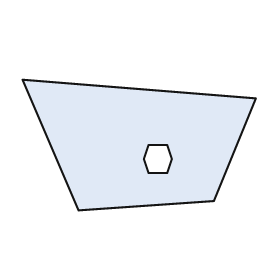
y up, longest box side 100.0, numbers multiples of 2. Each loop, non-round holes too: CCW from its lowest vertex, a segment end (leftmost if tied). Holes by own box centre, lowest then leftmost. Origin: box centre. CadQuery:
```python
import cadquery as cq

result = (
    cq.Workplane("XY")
    .moveTo(-26.0, -28.0)
    .lineTo(32.0, -24.0)
    .lineTo(50.0, 20.0)
    .lineTo(-50.0, 28.0)
    .close()
    .moveTo(4.0, -12.0)
    .lineTo(12.0, -12.0)
    .lineTo(14.0, -6.0)
    .lineTo(12.0, 0.0)
    .lineTo(4.0, 0.0)
    .lineTo(2.0, -6.0)
    .close()
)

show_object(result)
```